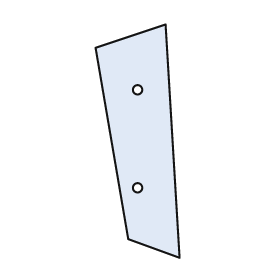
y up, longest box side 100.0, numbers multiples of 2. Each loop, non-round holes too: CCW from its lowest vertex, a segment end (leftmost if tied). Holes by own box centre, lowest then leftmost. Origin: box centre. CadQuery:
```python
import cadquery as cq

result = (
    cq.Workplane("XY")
    .moveTo(18.0, -50.0)
    .lineTo(12.0, 50.0)
    .lineTo(-18.0, 40.0)
    .lineTo(-4.0, -42.0)
    .close()
    .moveTo(0.0, -20.0)
    .circle(2.0)
    .moveTo(0.0, 22.0)
    .circle(2.0)
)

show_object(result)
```